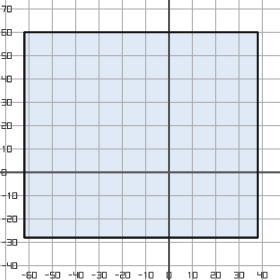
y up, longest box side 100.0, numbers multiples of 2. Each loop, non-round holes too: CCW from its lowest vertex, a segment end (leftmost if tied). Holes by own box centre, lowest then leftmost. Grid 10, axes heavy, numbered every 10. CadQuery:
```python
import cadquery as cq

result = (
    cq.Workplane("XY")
    .moveTo(-62.0, -28.0)
    .lineTo(38.0, -28.0)
    .lineTo(38.0, 60.0)
    .lineTo(-62.0, 60.0)
    .close()
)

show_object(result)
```